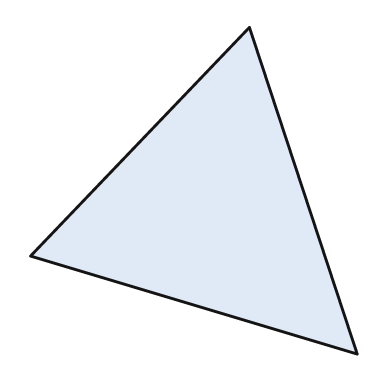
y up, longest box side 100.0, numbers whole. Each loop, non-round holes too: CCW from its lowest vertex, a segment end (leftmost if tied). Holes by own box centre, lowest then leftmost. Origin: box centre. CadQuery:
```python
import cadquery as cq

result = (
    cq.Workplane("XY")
    .moveTo(50.0, -50.0)
    .lineTo(17.0, 50.0)
    .lineTo(-50.0, -20.0)
    .close()
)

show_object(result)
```